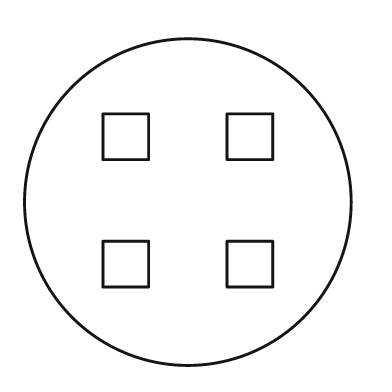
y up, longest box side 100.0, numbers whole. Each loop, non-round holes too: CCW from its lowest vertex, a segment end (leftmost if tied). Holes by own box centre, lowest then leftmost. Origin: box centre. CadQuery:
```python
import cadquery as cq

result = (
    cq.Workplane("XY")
    .moveTo(0.0, 0.0)
    .circle(50.0)
    .moveTo(-26.0, -26.0)
    .lineTo(-12.0, -26.0)
    .lineTo(-12.0, -12.0)
    .lineTo(-26.0, -12.0)
    .close()
    .moveTo(12.0, -26.0)
    .lineTo(26.0, -26.0)
    .lineTo(26.0, -12.0)
    .lineTo(12.0, -12.0)
    .close()
    .moveTo(-26.0, 13.0)
    .lineTo(-12.0, 13.0)
    .lineTo(-12.0, 27.0)
    .lineTo(-26.0, 27.0)
    .close()
    .moveTo(12.0, 13.0)
    .lineTo(26.0, 13.0)
    .lineTo(26.0, 27.0)
    .lineTo(12.0, 27.0)
    .close()
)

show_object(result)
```